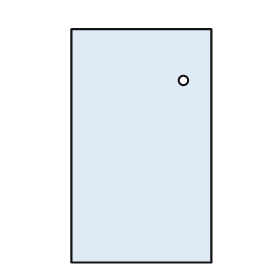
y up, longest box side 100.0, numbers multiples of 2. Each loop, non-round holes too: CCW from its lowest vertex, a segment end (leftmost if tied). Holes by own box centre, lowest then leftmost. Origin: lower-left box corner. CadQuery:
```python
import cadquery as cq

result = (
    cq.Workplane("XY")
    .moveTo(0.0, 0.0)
    .lineTo(60.0, 0.0)
    .lineTo(60.0, 100.0)
    .lineTo(0.0, 100.0)
    .close()
    .moveTo(48.0, 78.0)
    .circle(2.0)
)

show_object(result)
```